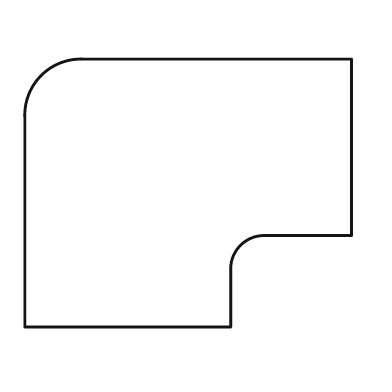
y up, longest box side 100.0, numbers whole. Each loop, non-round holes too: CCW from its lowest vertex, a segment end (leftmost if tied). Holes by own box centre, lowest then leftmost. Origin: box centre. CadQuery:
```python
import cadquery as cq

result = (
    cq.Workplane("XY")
    .moveTo(-50.0, -41.0)
    .lineTo(13.0, -41.0)
    .lineTo(13.0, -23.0)
    .threePointArc((16.0, -16.0), (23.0, -13.0))
    .lineTo(50.0, -13.0)
    .lineTo(50.0, 41.0)
    .lineTo(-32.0, 41.0)
    .threePointArc((-45.0, 36.0), (-50.0, 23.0))
    .close()
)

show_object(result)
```